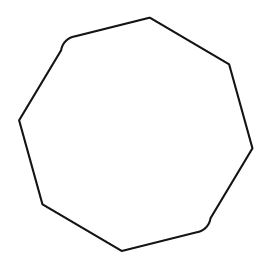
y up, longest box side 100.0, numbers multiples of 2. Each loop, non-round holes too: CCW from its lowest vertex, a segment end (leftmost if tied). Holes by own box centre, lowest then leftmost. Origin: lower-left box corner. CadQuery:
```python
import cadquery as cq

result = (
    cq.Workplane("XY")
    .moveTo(44.0, 0.0)
    .lineTo(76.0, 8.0)
    .threePointArc((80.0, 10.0), (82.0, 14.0))
    .lineTo(100.0, 44.0)
    .lineTo(90.0, 80.0)
    .lineTo(56.0, 100.0)
    .lineTo(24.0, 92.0)
    .threePointArc((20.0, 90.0), (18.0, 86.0))
    .lineTo(0.0, 56.0)
    .lineTo(10.0, 20.0)
    .close()
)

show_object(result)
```